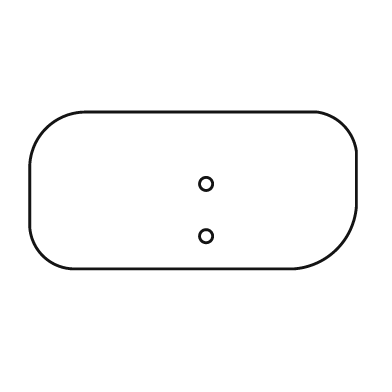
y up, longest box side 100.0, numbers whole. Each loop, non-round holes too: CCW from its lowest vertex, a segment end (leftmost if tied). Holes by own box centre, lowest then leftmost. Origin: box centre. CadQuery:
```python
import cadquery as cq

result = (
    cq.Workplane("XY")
    .moveTo(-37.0, -24.0)
    .lineTo(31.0, -24.0)
    .threePointArc((44.0, -18.0), (50.0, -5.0))
    .lineTo(50.0, 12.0)
    .threePointArc((46.0, 20.0), (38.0, 24.0))
    .lineTo(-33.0, 24.0)
    .threePointArc((-45.0, 19.0), (-50.0, 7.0))
    .lineTo(-50.0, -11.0)
    .threePointArc((-46.0, -20.0), (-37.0, -24.0))
    .close()
    .moveTo(4.0, -14.0)
    .circle(2.0)
    .moveTo(4.0, 2.0)
    .circle(2.0)
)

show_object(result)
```